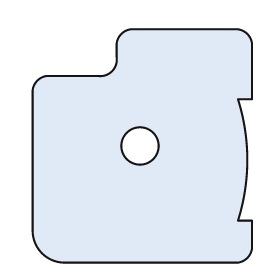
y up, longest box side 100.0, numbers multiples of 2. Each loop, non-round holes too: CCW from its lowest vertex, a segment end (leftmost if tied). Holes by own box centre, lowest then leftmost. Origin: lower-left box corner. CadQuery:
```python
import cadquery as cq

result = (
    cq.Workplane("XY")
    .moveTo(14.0, 0.0)
    .lineTo(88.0, 0.0)
    .threePointArc((92.0, 2.0), (94.0, 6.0))
    .lineTo(94.0, 18.0)
    .lineTo(88.0, 18.0)
    .threePointArc((92.0, 44.0), (88.0, 70.0))
    .lineTo(94.0, 70.0)
    .lineTo(94.0, 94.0)
    .threePointArc((92.0, 98.0), (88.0, 100.0))
    .lineTo(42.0, 100.0)
    .threePointArc((38.0, 98.0), (36.0, 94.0))
    .lineTo(36.0, 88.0)
    .threePointArc((34.0, 82.0), (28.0, 80.0))
    .lineTo(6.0, 80.0)
    .threePointArc((2.0, 78.0), (0.0, 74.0))
    .lineTo(0.0, 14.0)
    .threePointArc((4.0, 4.0), (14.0, 0.0))
    .close()
    .moveTo(46.0, 50.0)
    .circle(8.0)
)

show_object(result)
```